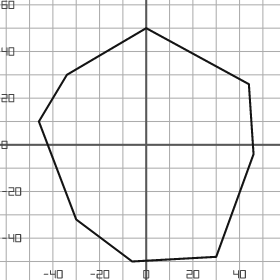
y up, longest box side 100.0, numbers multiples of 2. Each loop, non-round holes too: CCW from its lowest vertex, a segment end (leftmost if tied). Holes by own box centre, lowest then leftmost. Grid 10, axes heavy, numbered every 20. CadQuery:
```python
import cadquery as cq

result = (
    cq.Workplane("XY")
    .moveTo(-6.0, -50.0)
    .lineTo(30.0, -48.0)
    .lineTo(46.0, -4.0)
    .lineTo(44.0, 26.0)
    .lineTo(0.0, 50.0)
    .lineTo(-34.0, 30.0)
    .lineTo(-46.0, 10.0)
    .lineTo(-30.0, -32.0)
    .close()
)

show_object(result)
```